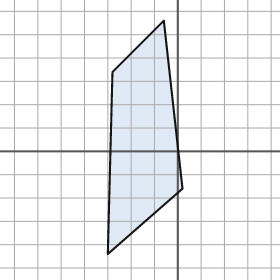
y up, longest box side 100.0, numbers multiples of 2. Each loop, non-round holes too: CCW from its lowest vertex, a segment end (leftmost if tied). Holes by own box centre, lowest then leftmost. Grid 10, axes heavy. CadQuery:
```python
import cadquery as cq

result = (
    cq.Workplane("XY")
    .moveTo(-30.0, -44.0)
    .lineTo(2.0, -16.0)
    .lineTo(-6.0, 56.0)
    .lineTo(-28.0, 34.0)
    .close()
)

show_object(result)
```